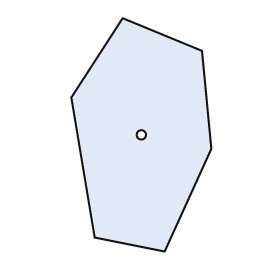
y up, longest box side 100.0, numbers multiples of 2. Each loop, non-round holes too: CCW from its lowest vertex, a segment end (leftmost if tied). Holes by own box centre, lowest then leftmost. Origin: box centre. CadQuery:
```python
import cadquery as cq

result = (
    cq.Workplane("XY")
    .moveTo(10.0, -50.0)
    .lineTo(30.0, -6.0)
    .lineTo(26.0, 36.0)
    .lineTo(-8.0, 50.0)
    .lineTo(-30.0, 16.0)
    .lineTo(-20.0, -44.0)
    .close()
    .moveTo(0.0, 0.0)
    .circle(2.0)
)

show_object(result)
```